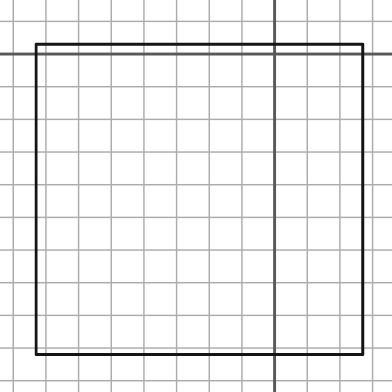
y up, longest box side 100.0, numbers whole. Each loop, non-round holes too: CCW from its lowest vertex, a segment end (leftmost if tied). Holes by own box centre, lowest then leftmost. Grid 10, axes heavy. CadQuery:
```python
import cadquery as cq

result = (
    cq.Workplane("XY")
    .moveTo(-73.0, -92.0)
    .lineTo(27.0, -92.0)
    .lineTo(27.0, 3.0)
    .lineTo(-73.0, 3.0)
    .close()
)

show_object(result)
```